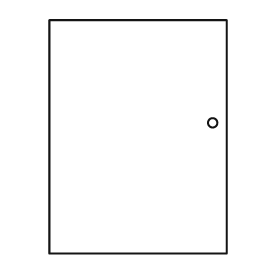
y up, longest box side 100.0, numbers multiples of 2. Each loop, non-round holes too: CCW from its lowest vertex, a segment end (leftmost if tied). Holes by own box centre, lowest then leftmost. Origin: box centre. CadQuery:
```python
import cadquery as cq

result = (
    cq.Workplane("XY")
    .moveTo(-38.0, -50.0)
    .lineTo(38.0, -50.0)
    .lineTo(38.0, 50.0)
    .lineTo(-38.0, 50.0)
    .close()
    .moveTo(32.0, 6.0)
    .circle(2.0)
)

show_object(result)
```